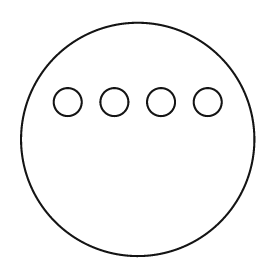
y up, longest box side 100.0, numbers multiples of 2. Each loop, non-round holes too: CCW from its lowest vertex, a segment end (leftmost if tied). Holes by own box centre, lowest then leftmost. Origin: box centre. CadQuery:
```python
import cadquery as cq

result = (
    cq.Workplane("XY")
    .moveTo(0.0, 0.0)
    .circle(50.0)
    .moveTo(-30.0, 16.0)
    .circle(6.0)
    .moveTo(-10.0, 16.0)
    .circle(6.0)
    .moveTo(10.0, 16.0)
    .circle(6.0)
    .moveTo(30.0, 16.0)
    .circle(6.0)
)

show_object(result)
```